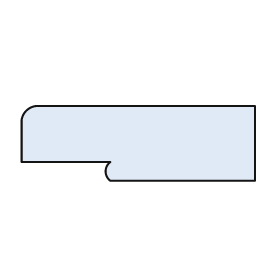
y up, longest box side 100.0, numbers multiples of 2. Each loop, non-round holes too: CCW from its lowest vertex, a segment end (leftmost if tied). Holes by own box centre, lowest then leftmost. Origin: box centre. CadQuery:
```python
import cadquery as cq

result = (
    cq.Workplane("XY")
    .moveTo(-12.0, -16.0)
    .lineTo(50.0, -16.0)
    .lineTo(50.0, 16.0)
    .lineTo(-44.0, 16.0)
    .threePointArc((-48.0, 14.0), (-50.0, 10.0))
    .lineTo(-50.0, -8.0)
    .lineTo(-12.0, -8.0)
    .threePointArc((-14.0, -12.0), (-12.0, -16.0))
    .close()
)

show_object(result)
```